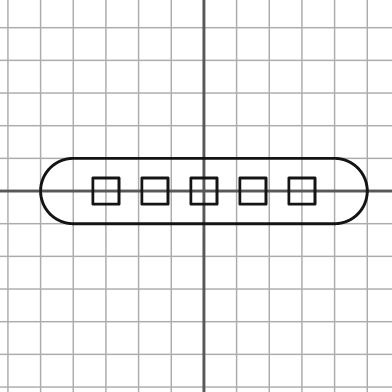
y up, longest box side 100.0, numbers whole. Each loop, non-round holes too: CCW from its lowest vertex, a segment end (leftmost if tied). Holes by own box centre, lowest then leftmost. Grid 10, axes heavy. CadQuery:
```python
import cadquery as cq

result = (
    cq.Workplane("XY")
    .moveTo(-40.0, -10.0)
    .lineTo(40.0, -10.0)
    .threePointArc((50.0, 0.0), (40.0, 10.0))
    .lineTo(-40.0, 10.0)
    .threePointArc((-50.0, 0.0), (-40.0, -10.0))
    .close()
    .moveTo(-34.0, -4.0)
    .lineTo(-26.0, -4.0)
    .lineTo(-26.0, 4.0)
    .lineTo(-34.0, 4.0)
    .close()
    .moveTo(-19.0, -4.0)
    .lineTo(-11.0, -4.0)
    .lineTo(-11.0, 4.0)
    .lineTo(-19.0, 4.0)
    .close()
    .moveTo(-4.0, -4.0)
    .lineTo(4.0, -4.0)
    .lineTo(4.0, 4.0)
    .lineTo(-4.0, 4.0)
    .close()
    .moveTo(11.0, -4.0)
    .lineTo(19.0, -4.0)
    .lineTo(19.0, 4.0)
    .lineTo(11.0, 4.0)
    .close()
    .moveTo(26.0, -4.0)
    .lineTo(34.0, -4.0)
    .lineTo(34.0, 4.0)
    .lineTo(26.0, 4.0)
    .close()
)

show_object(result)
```